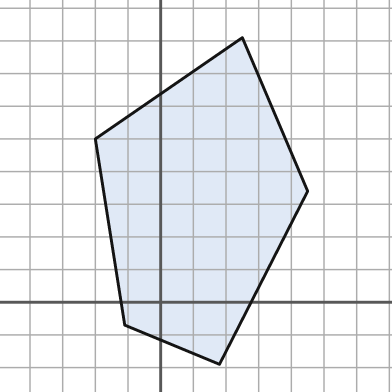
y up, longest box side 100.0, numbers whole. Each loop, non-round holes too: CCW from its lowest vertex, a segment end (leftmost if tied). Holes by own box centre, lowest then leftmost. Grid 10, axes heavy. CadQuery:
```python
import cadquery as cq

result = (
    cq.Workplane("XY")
    .moveTo(18.0, -19.0)
    .lineTo(45.0, 34.0)
    .lineTo(25.0, 81.0)
    .lineTo(-20.0, 50.0)
    .lineTo(-11.0, -7.0)
    .close()
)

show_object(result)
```